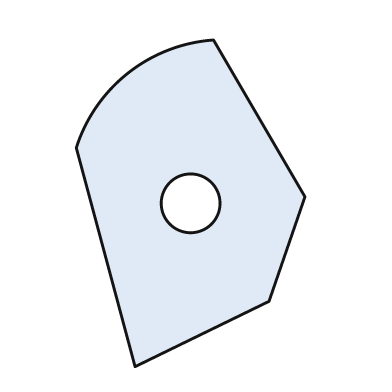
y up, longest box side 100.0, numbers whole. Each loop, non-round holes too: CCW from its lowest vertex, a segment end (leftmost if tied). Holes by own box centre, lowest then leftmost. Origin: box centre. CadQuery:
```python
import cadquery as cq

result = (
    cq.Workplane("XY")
    .moveTo(-17.0, -50.0)
    .lineTo(24.0, -30.0)
    .lineTo(35.0, 2.0)
    .lineTo(7.0, 50.0)
    .threePointArc((-19.0, 40.0), (-35.0, 17.0))
    .close()
    .moveTo(0.0, 0.0)
    .circle(9.0)
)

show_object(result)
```